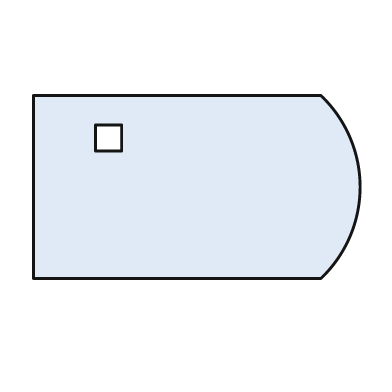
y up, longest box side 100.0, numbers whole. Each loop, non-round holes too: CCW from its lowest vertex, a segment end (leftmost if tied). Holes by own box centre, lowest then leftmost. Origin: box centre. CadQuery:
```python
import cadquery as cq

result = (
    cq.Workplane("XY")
    .moveTo(-50.0, -28.0)
    .lineTo(38.0, -28.0)
    .threePointArc((50.0, 0.0), (38.0, 28.0))
    .lineTo(-50.0, 28.0)
    .close()
    .moveTo(-31.0, 11.0)
    .lineTo(-23.0, 11.0)
    .lineTo(-23.0, 19.0)
    .lineTo(-31.0, 19.0)
    .close()
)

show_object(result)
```